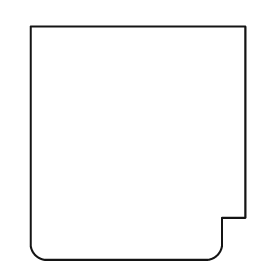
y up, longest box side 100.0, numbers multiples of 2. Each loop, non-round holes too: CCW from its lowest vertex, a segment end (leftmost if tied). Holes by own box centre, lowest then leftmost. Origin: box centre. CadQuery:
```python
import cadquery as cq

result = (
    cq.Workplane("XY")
    .moveTo(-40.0, -50.0)
    .lineTo(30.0, -50.0)
    .threePointArc((34.0, -48.0), (36.0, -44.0))
    .lineTo(36.0, -32.0)
    .lineTo(46.0, -32.0)
    .lineTo(46.0, 50.0)
    .lineTo(-46.0, 50.0)
    .lineTo(-46.0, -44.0)
    .threePointArc((-44.0, -48.0), (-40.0, -50.0))
    .close()
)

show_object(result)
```